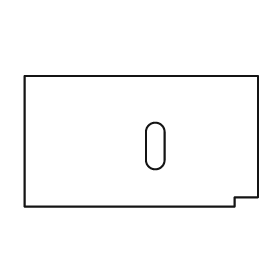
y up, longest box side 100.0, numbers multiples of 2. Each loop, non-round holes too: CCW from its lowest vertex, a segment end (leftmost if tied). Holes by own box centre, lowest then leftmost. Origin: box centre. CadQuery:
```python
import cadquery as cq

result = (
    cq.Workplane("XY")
    .moveTo(-50.0, -28.0)
    .lineTo(40.0, -28.0)
    .lineTo(40.0, -24.0)
    .lineTo(50.0, -24.0)
    .lineTo(50.0, 28.0)
    .lineTo(-50.0, 28.0)
    .close()
    .moveTo(2.0, -8.0)
    .threePointArc((6.0, -12.0), (10.0, -8.0))
    .lineTo(10.0, 4.0)
    .threePointArc((6.0, 8.0), (2.0, 4.0))
    .close()
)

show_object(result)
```